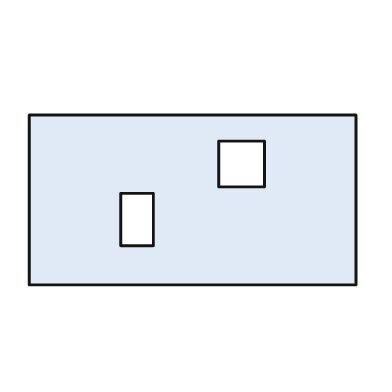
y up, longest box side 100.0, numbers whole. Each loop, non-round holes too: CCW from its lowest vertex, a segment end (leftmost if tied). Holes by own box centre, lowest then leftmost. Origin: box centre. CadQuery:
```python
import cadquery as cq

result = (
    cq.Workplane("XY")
    .moveTo(-50.0, -26.0)
    .lineTo(50.0, -26.0)
    .lineTo(50.0, 26.0)
    .lineTo(-50.0, 26.0)
    .close()
    .moveTo(-22.0, -14.0)
    .lineTo(-12.0, -14.0)
    .lineTo(-12.0, 2.0)
    .lineTo(-22.0, 2.0)
    .close()
    .moveTo(8.0, 4.0)
    .lineTo(22.0, 4.0)
    .lineTo(22.0, 18.0)
    .lineTo(8.0, 18.0)
    .close()
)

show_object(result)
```